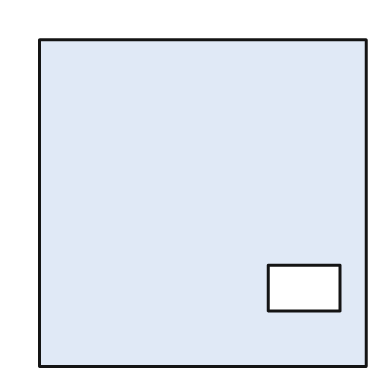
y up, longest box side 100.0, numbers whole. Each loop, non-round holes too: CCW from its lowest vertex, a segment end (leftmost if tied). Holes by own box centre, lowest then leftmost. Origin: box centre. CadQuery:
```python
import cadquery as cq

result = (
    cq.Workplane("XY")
    .moveTo(-50.0, -50.0)
    .lineTo(50.0, -50.0)
    .lineTo(50.0, 50.0)
    .lineTo(-50.0, 50.0)
    .close()
    .moveTo(20.0, -33.0)
    .lineTo(42.0, -33.0)
    .lineTo(42.0, -19.0)
    .lineTo(20.0, -19.0)
    .close()
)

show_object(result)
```